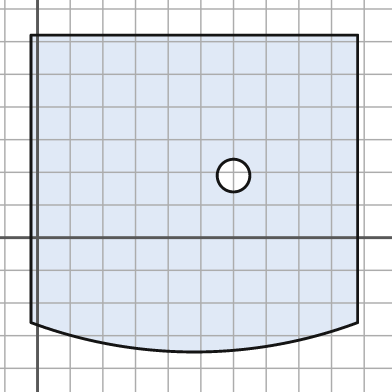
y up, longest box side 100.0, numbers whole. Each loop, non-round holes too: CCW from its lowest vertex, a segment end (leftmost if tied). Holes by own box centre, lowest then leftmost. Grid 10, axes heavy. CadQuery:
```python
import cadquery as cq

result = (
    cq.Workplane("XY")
    .moveTo(-2.0, -26.0)
    .threePointArc((48.0, -35.0), (98.0, -26.0))
    .lineTo(98.0, 62.0)
    .lineTo(-2.0, 62.0)
    .close()
    .moveTo(60.0, 19.0)
    .circle(5.0)
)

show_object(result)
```